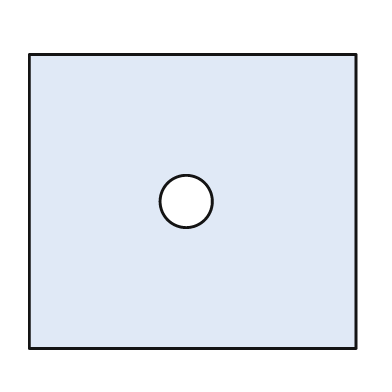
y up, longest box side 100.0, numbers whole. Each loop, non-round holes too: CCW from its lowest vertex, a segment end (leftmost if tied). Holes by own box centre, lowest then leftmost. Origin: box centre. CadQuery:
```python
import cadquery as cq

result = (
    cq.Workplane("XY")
    .moveTo(-50.0, -45.0)
    .lineTo(50.0, -45.0)
    .lineTo(50.0, 45.0)
    .lineTo(-50.0, 45.0)
    .close()
    .moveTo(-2.0, 0.0)
    .circle(8.0)
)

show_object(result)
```